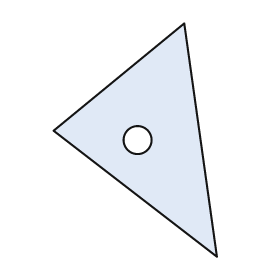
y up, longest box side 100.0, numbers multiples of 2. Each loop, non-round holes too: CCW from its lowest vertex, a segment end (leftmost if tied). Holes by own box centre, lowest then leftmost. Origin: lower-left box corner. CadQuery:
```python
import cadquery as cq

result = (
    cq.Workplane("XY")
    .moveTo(70.0, 0.0)
    .lineTo(56.0, 100.0)
    .lineTo(0.0, 54.0)
    .close()
    .moveTo(36.0, 50.0)
    .circle(6.0)
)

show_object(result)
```